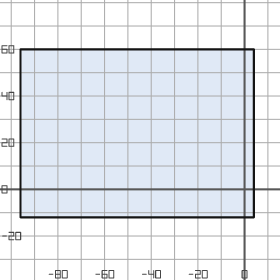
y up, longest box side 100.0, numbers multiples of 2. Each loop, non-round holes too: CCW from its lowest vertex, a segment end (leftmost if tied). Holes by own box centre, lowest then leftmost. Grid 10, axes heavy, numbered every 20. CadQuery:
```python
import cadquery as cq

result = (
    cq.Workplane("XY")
    .moveTo(-96.0, -12.0)
    .lineTo(4.0, -12.0)
    .lineTo(4.0, 60.0)
    .lineTo(-96.0, 60.0)
    .close()
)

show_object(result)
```